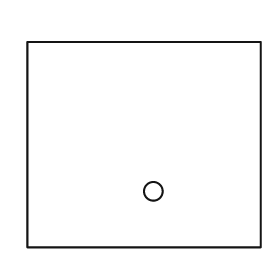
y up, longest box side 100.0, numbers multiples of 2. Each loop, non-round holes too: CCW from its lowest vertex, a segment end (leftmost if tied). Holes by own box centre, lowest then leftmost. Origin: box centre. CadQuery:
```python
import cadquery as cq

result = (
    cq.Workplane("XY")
    .moveTo(-50.0, -44.0)
    .lineTo(50.0, -44.0)
    .lineTo(50.0, 44.0)
    .lineTo(-50.0, 44.0)
    .close()
    .moveTo(4.0, -20.0)
    .circle(4.0)
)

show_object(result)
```